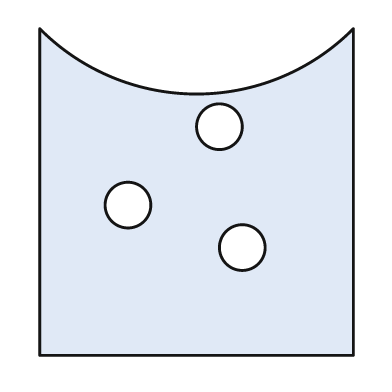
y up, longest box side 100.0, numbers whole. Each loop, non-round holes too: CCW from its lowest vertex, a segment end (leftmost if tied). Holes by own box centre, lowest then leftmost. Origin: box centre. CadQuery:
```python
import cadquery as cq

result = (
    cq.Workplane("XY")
    .moveTo(-48.0, -50.0)
    .lineTo(48.0, -50.0)
    .lineTo(48.0, 50.0)
    .threePointArc((0.0, 30.0), (-48.0, 50.0))
    .close()
    .moveTo(14.0, -17.0)
    .circle(7.0)
    .moveTo(-21.0, -4.0)
    .circle(7.0)
    .moveTo(7.0, 20.0)
    .circle(7.0)
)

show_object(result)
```